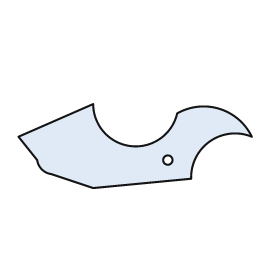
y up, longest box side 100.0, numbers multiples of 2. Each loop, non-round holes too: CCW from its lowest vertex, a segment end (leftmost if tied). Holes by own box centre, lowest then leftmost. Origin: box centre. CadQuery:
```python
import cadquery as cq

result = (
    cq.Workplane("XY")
    .moveTo(-18.0, -18.0)
    .lineTo(24.0, -14.0)
    .threePointArc((32.0, 2.0), (50.0, 4.0))
    .threePointArc((36.0, 16.0), (18.0, 14.0))
    .threePointArc((-2.0, 0.0), (-18.0, 18.0))
    .lineTo(-50.0, 4.0)
    .lineTo(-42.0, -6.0)
    .threePointArc((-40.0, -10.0), (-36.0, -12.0))
    .close()
    .moveTo(14.0, -6.0)
    .circle(2.0)
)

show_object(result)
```